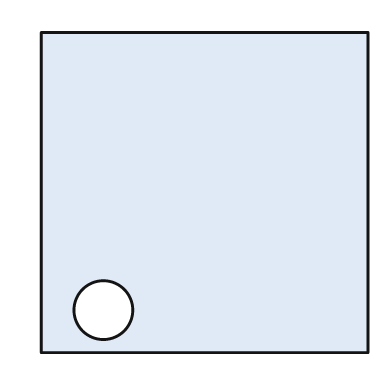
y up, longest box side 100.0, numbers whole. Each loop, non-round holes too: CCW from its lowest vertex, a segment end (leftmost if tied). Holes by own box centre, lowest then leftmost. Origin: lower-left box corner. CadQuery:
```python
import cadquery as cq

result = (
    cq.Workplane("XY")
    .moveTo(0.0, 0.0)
    .lineTo(100.0, 0.0)
    .lineTo(100.0, 98.0)
    .lineTo(0.0, 98.0)
    .close()
    .moveTo(19.0, 13.0)
    .circle(9.0)
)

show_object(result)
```